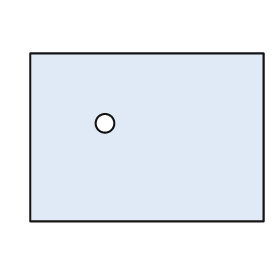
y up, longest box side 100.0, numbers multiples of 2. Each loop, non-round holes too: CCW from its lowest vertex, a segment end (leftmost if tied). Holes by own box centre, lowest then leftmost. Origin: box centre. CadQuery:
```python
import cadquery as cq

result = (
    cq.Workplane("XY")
    .moveTo(-50.0, -36.0)
    .lineTo(50.0, -36.0)
    .lineTo(50.0, 36.0)
    .lineTo(-50.0, 36.0)
    .close()
    .moveTo(-18.0, 6.0)
    .circle(4.0)
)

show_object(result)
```